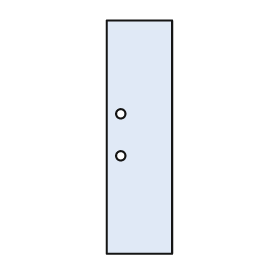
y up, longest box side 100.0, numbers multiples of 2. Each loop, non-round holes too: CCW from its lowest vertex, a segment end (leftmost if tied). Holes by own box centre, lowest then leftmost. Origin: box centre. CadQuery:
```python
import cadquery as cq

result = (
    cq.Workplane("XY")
    .moveTo(-14.0, -50.0)
    .lineTo(14.0, -50.0)
    .lineTo(14.0, 50.0)
    .lineTo(-14.0, 50.0)
    .close()
    .moveTo(-8.0, -8.0)
    .circle(2.0)
    .moveTo(-8.0, 10.0)
    .circle(2.0)
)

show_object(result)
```